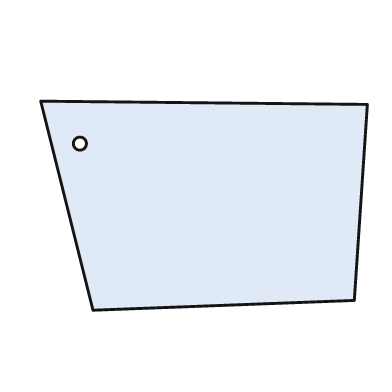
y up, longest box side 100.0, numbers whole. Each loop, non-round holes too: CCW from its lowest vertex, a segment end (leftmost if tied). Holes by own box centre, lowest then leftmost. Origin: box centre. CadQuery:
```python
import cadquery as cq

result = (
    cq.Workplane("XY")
    .moveTo(-34.0, -32.0)
    .lineTo(46.0, -29.0)
    .lineTo(50.0, 31.0)
    .lineTo(-50.0, 32.0)
    .close()
    .moveTo(-38.0, 19.0)
    .circle(2.0)
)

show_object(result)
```